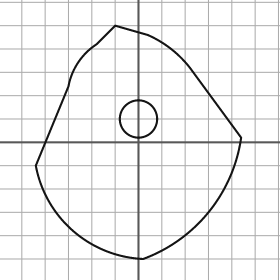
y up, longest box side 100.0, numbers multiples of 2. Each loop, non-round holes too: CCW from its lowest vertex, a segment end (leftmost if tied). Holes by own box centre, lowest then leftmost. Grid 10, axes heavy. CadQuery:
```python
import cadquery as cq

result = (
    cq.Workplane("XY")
    .moveTo(2.0, -50.0)
    .threePointArc((30.0, -30.0), (44.0, 2.0))
    .lineTo(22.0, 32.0)
    .threePointArc((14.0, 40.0), (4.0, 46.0))
    .lineTo(-10.0, 50.0)
    .lineTo(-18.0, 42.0)
    .threePointArc((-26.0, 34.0), (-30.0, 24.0))
    .lineTo(-44.0, -10.0)
    .threePointArc((-28.0, -38.0), (2.0, -50.0))
    .close()
    .moveTo(0.0, 10.0)
    .circle(8.0)
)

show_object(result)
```